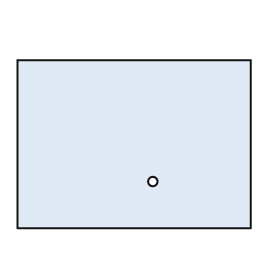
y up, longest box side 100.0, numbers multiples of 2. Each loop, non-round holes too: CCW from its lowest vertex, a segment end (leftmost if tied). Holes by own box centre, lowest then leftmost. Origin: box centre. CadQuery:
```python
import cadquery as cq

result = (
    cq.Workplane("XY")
    .moveTo(-50.0, -36.0)
    .lineTo(50.0, -36.0)
    .lineTo(50.0, 36.0)
    .lineTo(-50.0, 36.0)
    .close()
    .moveTo(8.0, -16.0)
    .circle(2.0)
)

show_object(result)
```